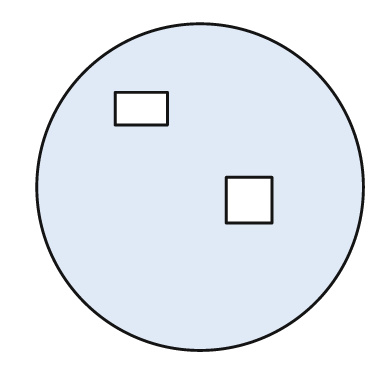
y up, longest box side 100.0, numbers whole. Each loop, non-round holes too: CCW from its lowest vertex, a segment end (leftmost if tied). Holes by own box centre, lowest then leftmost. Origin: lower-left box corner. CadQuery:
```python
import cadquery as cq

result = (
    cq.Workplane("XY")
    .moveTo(50.0, 50.0)
    .circle(50.0)
    .moveTo(58.0, 39.0)
    .lineTo(72.0, 39.0)
    .lineTo(72.0, 53.0)
    .lineTo(58.0, 53.0)
    .close()
    .moveTo(24.0, 69.0)
    .lineTo(40.0, 69.0)
    .lineTo(40.0, 79.0)
    .lineTo(24.0, 79.0)
    .close()
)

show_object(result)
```